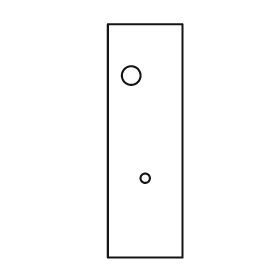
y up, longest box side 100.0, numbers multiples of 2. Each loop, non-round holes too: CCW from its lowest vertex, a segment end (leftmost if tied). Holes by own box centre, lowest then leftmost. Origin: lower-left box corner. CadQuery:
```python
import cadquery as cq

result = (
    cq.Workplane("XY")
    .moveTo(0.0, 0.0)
    .lineTo(32.0, 0.0)
    .lineTo(32.0, 100.0)
    .lineTo(0.0, 100.0)
    .close()
    .moveTo(16.0, 34.0)
    .circle(2.0)
    .moveTo(10.0, 78.0)
    .circle(4.0)
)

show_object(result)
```